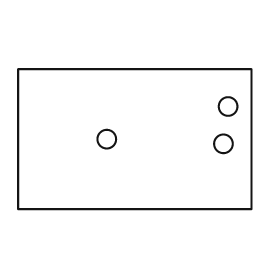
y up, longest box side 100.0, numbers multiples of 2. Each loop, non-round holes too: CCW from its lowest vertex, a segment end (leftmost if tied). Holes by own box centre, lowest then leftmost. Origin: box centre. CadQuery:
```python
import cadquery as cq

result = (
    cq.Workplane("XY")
    .moveTo(-50.0, -30.0)
    .lineTo(50.0, -30.0)
    .lineTo(50.0, 30.0)
    .lineTo(-50.0, 30.0)
    .close()
    .moveTo(38.0, -2.0)
    .circle(4.0)
    .moveTo(-12.0, 0.0)
    .circle(4.0)
    .moveTo(40.0, 14.0)
    .circle(4.0)
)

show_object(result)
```